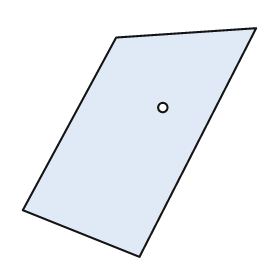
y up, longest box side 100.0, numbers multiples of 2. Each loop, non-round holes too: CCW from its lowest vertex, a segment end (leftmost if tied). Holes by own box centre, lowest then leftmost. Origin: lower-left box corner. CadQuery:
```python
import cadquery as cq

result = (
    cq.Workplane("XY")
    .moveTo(50.0, 0.0)
    .lineTo(100.0, 98.0)
    .lineTo(40.0, 94.0)
    .lineTo(0.0, 20.0)
    .close()
    .moveTo(60.0, 64.0)
    .circle(2.0)
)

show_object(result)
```